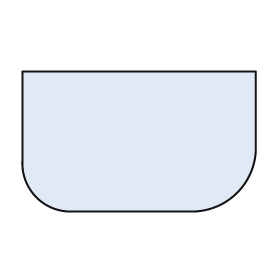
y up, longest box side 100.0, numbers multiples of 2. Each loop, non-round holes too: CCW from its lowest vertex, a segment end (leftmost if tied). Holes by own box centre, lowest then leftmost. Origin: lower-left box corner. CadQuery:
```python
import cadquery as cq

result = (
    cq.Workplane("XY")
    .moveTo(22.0, 0.0)
    .lineTo(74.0, 0.0)
    .threePointArc((92.0, 8.0), (100.0, 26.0))
    .lineTo(100.0, 60.0)
    .lineTo(0.0, 60.0)
    .lineTo(0.0, 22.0)
    .threePointArc((6.0, 6.0), (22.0, 0.0))
    .close()
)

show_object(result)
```